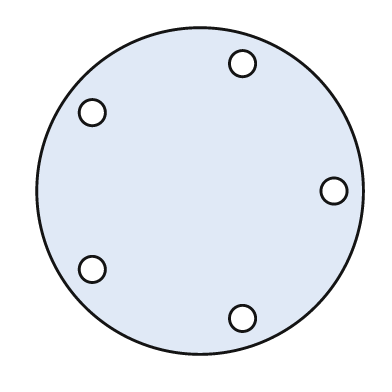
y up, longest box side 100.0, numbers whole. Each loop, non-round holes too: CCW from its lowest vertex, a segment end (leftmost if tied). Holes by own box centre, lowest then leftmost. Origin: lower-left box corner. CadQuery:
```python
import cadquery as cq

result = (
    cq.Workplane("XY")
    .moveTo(50.0, 50.0)
    .circle(50.0)
    .moveTo(63.0, 11.0)
    .circle(4.0)
    .moveTo(17.0, 26.0)
    .circle(4.0)
    .moveTo(91.0, 50.0)
    .circle(4.0)
    .moveTo(17.0, 74.0)
    .circle(4.0)
    .moveTo(63.0, 89.0)
    .circle(4.0)
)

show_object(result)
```